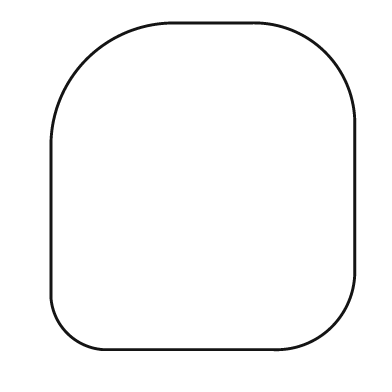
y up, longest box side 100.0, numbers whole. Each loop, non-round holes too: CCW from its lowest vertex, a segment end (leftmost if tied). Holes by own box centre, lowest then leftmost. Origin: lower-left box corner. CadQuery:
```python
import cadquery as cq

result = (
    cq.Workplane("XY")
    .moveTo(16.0, 0.0)
    .lineTo(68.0, 0.0)
    .threePointArc((86.0, 7.0), (93.0, 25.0))
    .lineTo(93.0, 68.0)
    .threePointArc((84.0, 91.0), (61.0, 100.0))
    .lineTo(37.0, 100.0)
    .threePointArc((11.0, 89.0), (0.0, 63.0))
    .lineTo(0.0, 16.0)
    .threePointArc((5.0, 5.0), (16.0, 0.0))
    .close()
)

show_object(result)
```